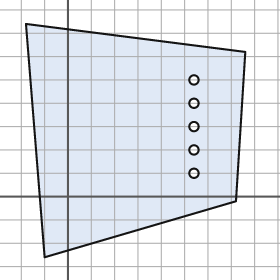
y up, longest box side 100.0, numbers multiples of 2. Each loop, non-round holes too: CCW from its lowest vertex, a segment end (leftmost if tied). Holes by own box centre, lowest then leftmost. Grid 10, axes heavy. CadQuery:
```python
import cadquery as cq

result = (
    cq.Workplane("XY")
    .moveTo(-10.0, -26.0)
    .lineTo(72.0, -2.0)
    .lineTo(76.0, 62.0)
    .lineTo(-18.0, 74.0)
    .close()
    .moveTo(54.0, 10.0)
    .circle(2.0)
    .moveTo(54.0, 20.0)
    .circle(2.0)
    .moveTo(54.0, 30.0)
    .circle(2.0)
    .moveTo(54.0, 40.0)
    .circle(2.0)
    .moveTo(54.0, 50.0)
    .circle(2.0)
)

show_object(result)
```